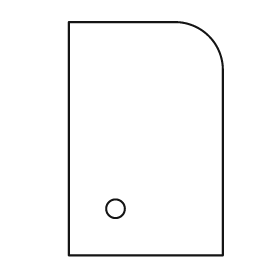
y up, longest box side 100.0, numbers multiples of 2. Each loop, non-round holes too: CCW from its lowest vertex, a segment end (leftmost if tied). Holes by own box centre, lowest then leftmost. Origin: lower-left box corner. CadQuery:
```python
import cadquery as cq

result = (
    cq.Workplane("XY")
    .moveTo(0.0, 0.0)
    .lineTo(66.0, 0.0)
    .lineTo(66.0, 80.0)
    .threePointArc((60.0, 94.0), (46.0, 100.0))
    .lineTo(0.0, 100.0)
    .close()
    .moveTo(20.0, 20.0)
    .circle(4.0)
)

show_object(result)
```